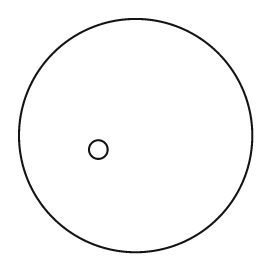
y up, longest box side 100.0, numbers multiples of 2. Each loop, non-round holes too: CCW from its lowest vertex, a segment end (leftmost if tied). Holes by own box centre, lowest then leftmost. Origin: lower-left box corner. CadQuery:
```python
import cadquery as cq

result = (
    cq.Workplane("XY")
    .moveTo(50.0, 50.0)
    .circle(50.0)
    .moveTo(34.0, 44.0)
    .circle(4.0)
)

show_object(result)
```